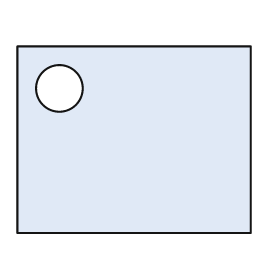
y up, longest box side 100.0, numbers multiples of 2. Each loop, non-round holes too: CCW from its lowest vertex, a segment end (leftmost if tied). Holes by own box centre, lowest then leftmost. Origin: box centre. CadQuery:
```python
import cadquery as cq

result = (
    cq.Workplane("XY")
    .moveTo(-50.0, -40.0)
    .lineTo(50.0, -40.0)
    .lineTo(50.0, 40.0)
    .lineTo(-50.0, 40.0)
    .close()
    .moveTo(-32.0, 22.0)
    .circle(10.0)
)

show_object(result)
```